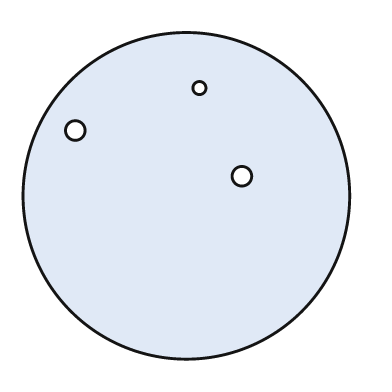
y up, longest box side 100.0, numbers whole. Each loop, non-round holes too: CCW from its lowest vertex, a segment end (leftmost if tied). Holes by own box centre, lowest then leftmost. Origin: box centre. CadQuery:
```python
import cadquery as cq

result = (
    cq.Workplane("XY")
    .moveTo(0.0, 0.0)
    .circle(50.0)
    .moveTo(17.0, 6.0)
    .circle(3.0)
    .moveTo(-34.0, 20.0)
    .circle(3.0)
    .moveTo(4.0, 33.0)
    .circle(2.0)
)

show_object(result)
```